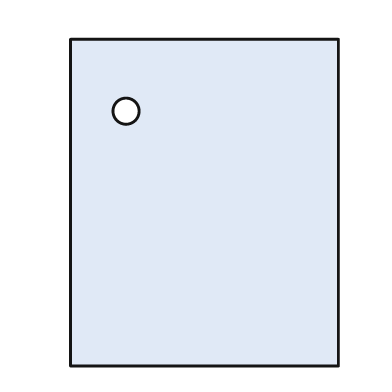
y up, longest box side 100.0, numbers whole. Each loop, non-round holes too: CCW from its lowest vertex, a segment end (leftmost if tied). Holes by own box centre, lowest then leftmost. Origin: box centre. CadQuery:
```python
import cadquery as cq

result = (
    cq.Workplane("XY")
    .moveTo(-41.0, -50.0)
    .lineTo(41.0, -50.0)
    .lineTo(41.0, 50.0)
    .lineTo(-41.0, 50.0)
    .close()
    .moveTo(-24.0, 28.0)
    .circle(4.0)
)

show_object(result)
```